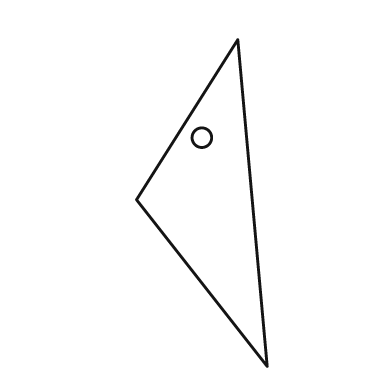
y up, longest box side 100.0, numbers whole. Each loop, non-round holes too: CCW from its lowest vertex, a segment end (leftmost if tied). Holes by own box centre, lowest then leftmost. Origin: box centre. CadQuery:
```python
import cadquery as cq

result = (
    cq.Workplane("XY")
    .moveTo(20.0, -50.0)
    .lineTo(11.0, 50.0)
    .lineTo(-20.0, 1.0)
    .close()
    .moveTo(0.0, 20.0)
    .circle(3.0)
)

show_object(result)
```